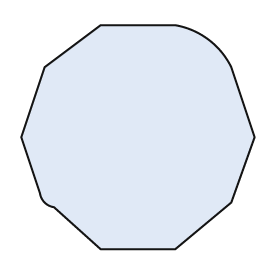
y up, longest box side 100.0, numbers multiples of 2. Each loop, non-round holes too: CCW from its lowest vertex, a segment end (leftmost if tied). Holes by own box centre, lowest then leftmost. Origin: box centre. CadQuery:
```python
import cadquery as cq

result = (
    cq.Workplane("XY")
    .moveTo(-16.0, -48.0)
    .lineTo(16.0, -48.0)
    .lineTo(40.0, -28.0)
    .lineTo(50.0, 0.0)
    .lineTo(40.0, 30.0)
    .threePointArc((30.0, 42.0), (16.0, 48.0))
    .lineTo(-16.0, 48.0)
    .lineTo(-40.0, 30.0)
    .lineTo(-50.0, 0.0)
    .lineTo(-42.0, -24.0)
    .threePointArc((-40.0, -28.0), (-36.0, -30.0))
    .close()
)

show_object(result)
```